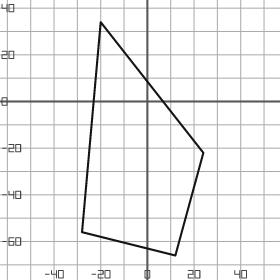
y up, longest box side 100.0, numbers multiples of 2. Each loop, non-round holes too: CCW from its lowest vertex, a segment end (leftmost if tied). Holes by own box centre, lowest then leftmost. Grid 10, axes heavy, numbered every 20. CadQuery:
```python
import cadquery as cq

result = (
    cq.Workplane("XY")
    .moveTo(12.0, -66.0)
    .lineTo(24.0, -22.0)
    .lineTo(-20.0, 34.0)
    .lineTo(-28.0, -56.0)
    .close()
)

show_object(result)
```